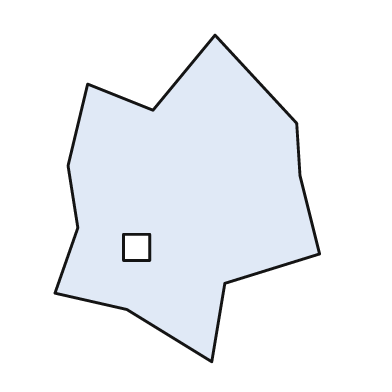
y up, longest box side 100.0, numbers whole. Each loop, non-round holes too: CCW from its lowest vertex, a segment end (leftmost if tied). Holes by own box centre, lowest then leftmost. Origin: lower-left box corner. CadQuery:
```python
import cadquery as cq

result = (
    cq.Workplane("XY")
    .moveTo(48.0, 0.0)
    .lineTo(52.0, 24.0)
    .lineTo(81.0, 33.0)
    .lineTo(75.0, 57.0)
    .lineTo(74.0, 73.0)
    .lineTo(49.0, 100.0)
    .lineTo(30.0, 77.0)
    .lineTo(10.0, 85.0)
    .lineTo(4.0, 60.0)
    .lineTo(7.0, 41.0)
    .lineTo(0.0, 21.0)
    .lineTo(22.0, 16.0)
    .close()
    .moveTo(21.0, 31.0)
    .lineTo(29.0, 31.0)
    .lineTo(29.0, 39.0)
    .lineTo(21.0, 39.0)
    .close()
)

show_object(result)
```